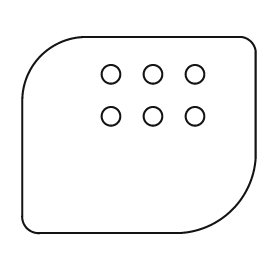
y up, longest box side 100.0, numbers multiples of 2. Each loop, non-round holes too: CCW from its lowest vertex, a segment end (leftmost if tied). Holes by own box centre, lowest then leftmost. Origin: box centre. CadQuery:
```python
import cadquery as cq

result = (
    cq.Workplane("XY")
    .moveTo(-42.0, -42.0)
    .lineTo(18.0, -42.0)
    .threePointArc((40.0, -32.0), (50.0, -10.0))
    .lineTo(50.0, 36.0)
    .threePointArc((48.0, 40.0), (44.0, 42.0))
    .lineTo(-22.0, 42.0)
    .threePointArc((-42.0, 34.0), (-50.0, 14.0))
    .lineTo(-50.0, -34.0)
    .threePointArc((-48.0, -40.0), (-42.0, -42.0))
    .close()
    .moveTo(-12.0, 8.0)
    .circle(4.0)
    .moveTo(6.0, 8.0)
    .circle(4.0)
    .moveTo(24.0, 8.0)
    .circle(4.0)
    .moveTo(-12.0, 26.0)
    .circle(4.0)
    .moveTo(6.0, 26.0)
    .circle(4.0)
    .moveTo(24.0, 26.0)
    .circle(4.0)
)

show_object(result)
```